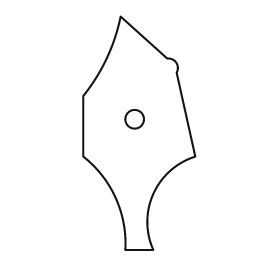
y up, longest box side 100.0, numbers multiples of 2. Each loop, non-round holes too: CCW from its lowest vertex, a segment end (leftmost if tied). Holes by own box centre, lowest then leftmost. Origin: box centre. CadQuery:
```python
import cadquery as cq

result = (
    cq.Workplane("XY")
    .moveTo(-6.0, -50.0)
    .lineTo(6.0, -50.0)
    .threePointArc((6.0, -26.0), (24.0, -10.0))
    .lineTo(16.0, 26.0)
    .threePointArc((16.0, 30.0), (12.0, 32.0))
    .lineTo(-8.0, 50.0)
    .threePointArc((-14.0, 32.0), (-24.0, 16.0))
    .lineTo(-24.0, -10.0)
    .threePointArc((-10.0, -28.0), (-6.0, -50.0))
    .close()
    .moveTo(-2.0, 6.0)
    .circle(4.0)
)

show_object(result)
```